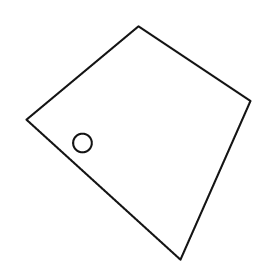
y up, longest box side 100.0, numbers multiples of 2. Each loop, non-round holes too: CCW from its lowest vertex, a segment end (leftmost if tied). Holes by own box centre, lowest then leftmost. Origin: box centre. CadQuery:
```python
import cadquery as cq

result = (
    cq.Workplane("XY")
    .moveTo(18.0, -50.0)
    .lineTo(48.0, 18.0)
    .lineTo(0.0, 50.0)
    .lineTo(-48.0, 10.0)
    .close()
    .moveTo(-24.0, 0.0)
    .circle(4.0)
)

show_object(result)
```